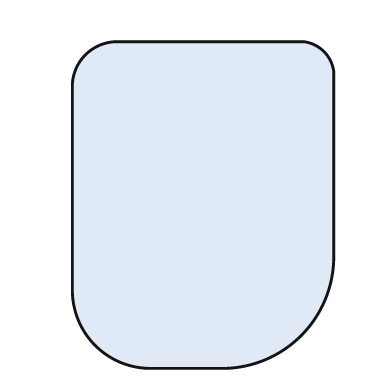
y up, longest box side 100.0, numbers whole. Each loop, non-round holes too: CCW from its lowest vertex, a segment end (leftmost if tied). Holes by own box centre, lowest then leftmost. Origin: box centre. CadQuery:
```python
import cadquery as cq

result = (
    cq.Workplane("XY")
    .moveTo(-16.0, -50.0)
    .lineTo(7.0, -50.0)
    .threePointArc((30.0, -40.0), (40.0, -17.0))
    .lineTo(40.0, 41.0)
    .threePointArc((37.0, 47.0), (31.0, 50.0))
    .lineTo(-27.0, 50.0)
    .threePointArc((-36.0, 46.0), (-40.0, 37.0))
    .lineTo(-40.0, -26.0)
    .threePointArc((-33.0, -43.0), (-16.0, -50.0))
    .close()
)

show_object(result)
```